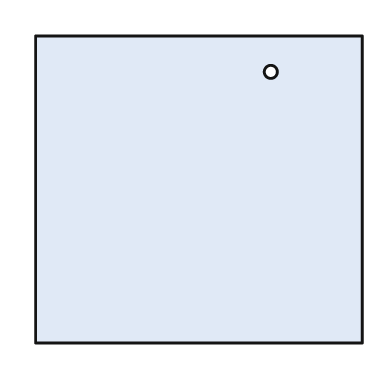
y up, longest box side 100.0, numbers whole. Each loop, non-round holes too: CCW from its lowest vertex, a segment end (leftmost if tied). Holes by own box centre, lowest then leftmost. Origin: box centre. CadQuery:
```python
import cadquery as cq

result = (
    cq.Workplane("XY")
    .moveTo(-50.0, -47.0)
    .lineTo(50.0, -47.0)
    .lineTo(50.0, 47.0)
    .lineTo(-50.0, 47.0)
    .close()
    .moveTo(22.0, 36.0)
    .circle(2.0)
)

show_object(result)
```